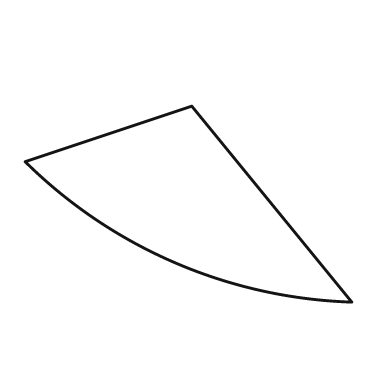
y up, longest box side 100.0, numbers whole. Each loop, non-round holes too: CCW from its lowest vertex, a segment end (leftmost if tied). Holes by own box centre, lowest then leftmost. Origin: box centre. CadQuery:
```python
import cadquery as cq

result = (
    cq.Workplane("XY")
    .moveTo(50.0, -30.0)
    .lineTo(1.0, 30.0)
    .lineTo(-50.0, 13.0)
    .threePointArc((-4.0, -18.0), (50.0, -30.0))
    .close()
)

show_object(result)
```